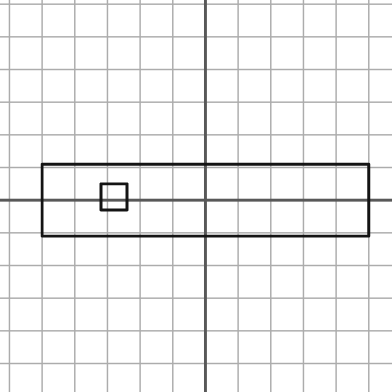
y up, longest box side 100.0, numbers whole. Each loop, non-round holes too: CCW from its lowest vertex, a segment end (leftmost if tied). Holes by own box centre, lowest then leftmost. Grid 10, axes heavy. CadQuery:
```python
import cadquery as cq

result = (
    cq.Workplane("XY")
    .moveTo(-50.0, -11.0)
    .lineTo(50.0, -11.0)
    .lineTo(50.0, 11.0)
    .lineTo(-50.0, 11.0)
    .close()
    .moveTo(-32.0, -3.0)
    .lineTo(-24.0, -3.0)
    .lineTo(-24.0, 5.0)
    .lineTo(-32.0, 5.0)
    .close()
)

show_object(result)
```